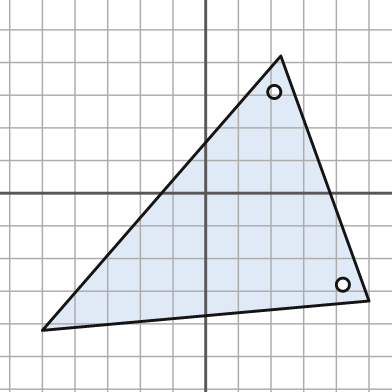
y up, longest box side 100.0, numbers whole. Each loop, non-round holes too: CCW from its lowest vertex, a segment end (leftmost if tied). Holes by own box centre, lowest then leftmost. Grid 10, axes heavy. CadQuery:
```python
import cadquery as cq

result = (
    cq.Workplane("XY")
    .moveTo(-50.0, -42.0)
    .lineTo(50.0, -33.0)
    .lineTo(23.0, 42.0)
    .close()
    .moveTo(42.0, -28.0)
    .circle(2.0)
    .moveTo(21.0, 31.0)
    .circle(2.0)
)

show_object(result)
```